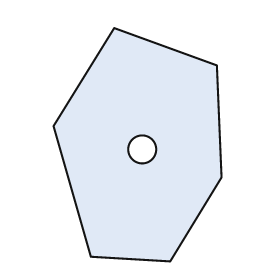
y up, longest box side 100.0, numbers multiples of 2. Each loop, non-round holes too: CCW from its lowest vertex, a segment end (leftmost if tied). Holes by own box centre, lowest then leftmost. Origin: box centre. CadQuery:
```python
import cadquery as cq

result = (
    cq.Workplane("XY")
    .moveTo(14.0, -50.0)
    .lineTo(36.0, -14.0)
    .lineTo(34.0, 34.0)
    .lineTo(-10.0, 50.0)
    .lineTo(-36.0, 8.0)
    .lineTo(-20.0, -48.0)
    .close()
    .moveTo(2.0, -2.0)
    .circle(6.0)
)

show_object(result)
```